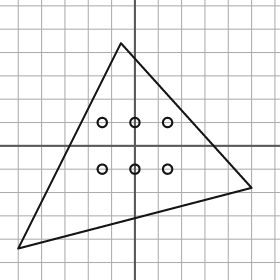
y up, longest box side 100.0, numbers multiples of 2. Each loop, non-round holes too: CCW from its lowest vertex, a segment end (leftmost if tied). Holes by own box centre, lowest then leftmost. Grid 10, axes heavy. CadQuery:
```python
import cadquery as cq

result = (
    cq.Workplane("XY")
    .moveTo(-50.0, -44.0)
    .lineTo(50.0, -18.0)
    .lineTo(-6.0, 44.0)
    .close()
    .moveTo(-14.0, -10.0)
    .circle(2.0)
    .moveTo(0.0, -10.0)
    .circle(2.0)
    .moveTo(14.0, -10.0)
    .circle(2.0)
    .moveTo(-14.0, 10.0)
    .circle(2.0)
    .moveTo(0.0, 10.0)
    .circle(2.0)
    .moveTo(14.0, 10.0)
    .circle(2.0)
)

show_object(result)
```